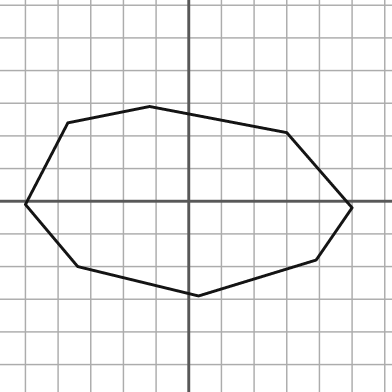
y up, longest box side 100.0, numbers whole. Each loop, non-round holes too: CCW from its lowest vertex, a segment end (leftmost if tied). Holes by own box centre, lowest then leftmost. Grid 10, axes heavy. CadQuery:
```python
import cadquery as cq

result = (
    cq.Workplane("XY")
    .moveTo(3.0, -29.0)
    .lineTo(39.0, -18.0)
    .lineTo(50.0, -2.0)
    .lineTo(30.0, 21.0)
    .lineTo(-12.0, 29.0)
    .lineTo(-37.0, 24.0)
    .lineTo(-50.0, -1.0)
    .lineTo(-34.0, -20.0)
    .close()
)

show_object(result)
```